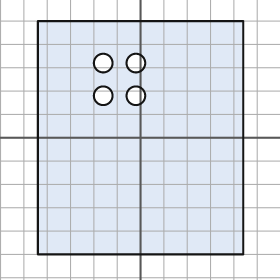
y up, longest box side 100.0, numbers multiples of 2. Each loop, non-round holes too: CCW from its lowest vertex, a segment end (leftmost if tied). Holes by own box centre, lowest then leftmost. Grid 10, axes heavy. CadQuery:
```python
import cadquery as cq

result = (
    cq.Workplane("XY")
    .moveTo(-44.0, -50.0)
    .lineTo(44.0, -50.0)
    .lineTo(44.0, 50.0)
    .lineTo(-44.0, 50.0)
    .close()
    .moveTo(-16.0, 18.0)
    .circle(4.0)
    .moveTo(-2.0, 18.0)
    .circle(4.0)
    .moveTo(-16.0, 32.0)
    .circle(4.0)
    .moveTo(-2.0, 32.0)
    .circle(4.0)
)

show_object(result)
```